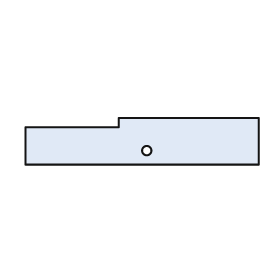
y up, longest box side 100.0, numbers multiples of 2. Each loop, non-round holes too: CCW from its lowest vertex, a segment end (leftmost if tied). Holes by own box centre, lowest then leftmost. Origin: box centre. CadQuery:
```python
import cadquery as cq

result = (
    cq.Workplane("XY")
    .moveTo(-50.0, -10.0)
    .lineTo(50.0, -10.0)
    .lineTo(50.0, 10.0)
    .lineTo(-10.0, 10.0)
    .lineTo(-10.0, 6.0)
    .lineTo(-50.0, 6.0)
    .close()
    .moveTo(2.0, -4.0)
    .circle(2.0)
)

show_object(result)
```